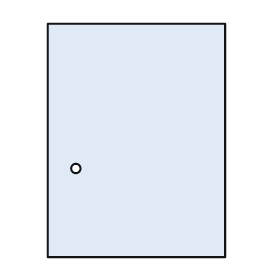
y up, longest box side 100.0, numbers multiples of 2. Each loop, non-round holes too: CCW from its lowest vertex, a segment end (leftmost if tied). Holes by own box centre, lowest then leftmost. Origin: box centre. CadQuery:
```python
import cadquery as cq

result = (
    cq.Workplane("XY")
    .moveTo(-38.0, -50.0)
    .lineTo(38.0, -50.0)
    .lineTo(38.0, 50.0)
    .lineTo(-38.0, 50.0)
    .close()
    .moveTo(-26.0, -12.0)
    .circle(2.0)
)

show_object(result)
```